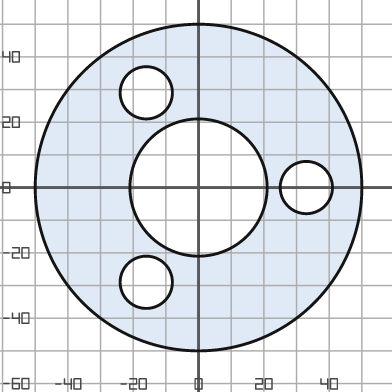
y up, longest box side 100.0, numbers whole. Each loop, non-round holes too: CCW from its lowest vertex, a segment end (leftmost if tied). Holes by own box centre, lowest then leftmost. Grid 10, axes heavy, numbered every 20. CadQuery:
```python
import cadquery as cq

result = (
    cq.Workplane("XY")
    .moveTo(0.0, 0.0)
    .circle(50.0)
    .moveTo(-16.0, -29.0)
    .circle(8.0)
    .moveTo(0.0, 0.0)
    .circle(21.0)
    .moveTo(33.0, 0.0)
    .circle(8.0)
    .moveTo(-16.0, 29.0)
    .circle(8.0)
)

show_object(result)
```